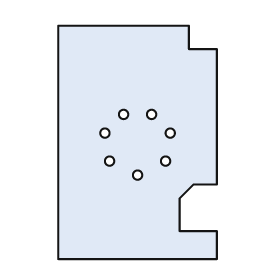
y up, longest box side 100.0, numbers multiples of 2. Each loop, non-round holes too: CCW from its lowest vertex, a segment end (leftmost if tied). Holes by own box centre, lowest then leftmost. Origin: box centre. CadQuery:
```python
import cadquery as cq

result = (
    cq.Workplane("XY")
    .moveTo(-34.0, -50.0)
    .lineTo(34.0, -50.0)
    .lineTo(34.0, -38.0)
    .lineTo(18.0, -38.0)
    .lineTo(18.0, -24.0)
    .lineTo(24.0, -18.0)
    .lineTo(34.0, -18.0)
    .lineTo(34.0, 40.0)
    .lineTo(22.0, 40.0)
    .lineTo(22.0, 50.0)
    .lineTo(-34.0, 50.0)
    .close()
    .moveTo(0.0, -14.0)
    .circle(2.0)
    .moveTo(-12.0, -8.0)
    .circle(2.0)
    .moveTo(12.0, -8.0)
    .circle(2.0)
    .moveTo(-14.0, 4.0)
    .circle(2.0)
    .moveTo(14.0, 4.0)
    .circle(2.0)
    .moveTo(-6.0, 12.0)
    .circle(2.0)
    .moveTo(6.0, 12.0)
    .circle(2.0)
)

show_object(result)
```